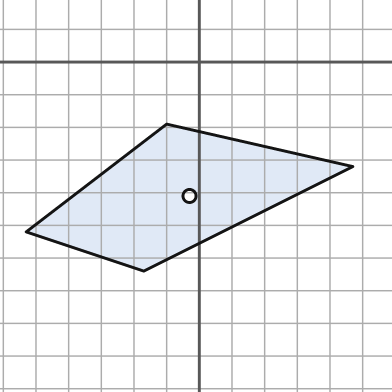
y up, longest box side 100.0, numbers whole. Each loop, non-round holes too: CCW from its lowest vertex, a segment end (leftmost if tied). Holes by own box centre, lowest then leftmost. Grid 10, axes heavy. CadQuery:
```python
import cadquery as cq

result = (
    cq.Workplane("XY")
    .moveTo(-17.0, -64.0)
    .lineTo(47.0, -32.0)
    .lineTo(-10.0, -19.0)
    .lineTo(-53.0, -52.0)
    .close()
    .moveTo(-3.0, -41.0)
    .circle(2.0)
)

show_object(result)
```